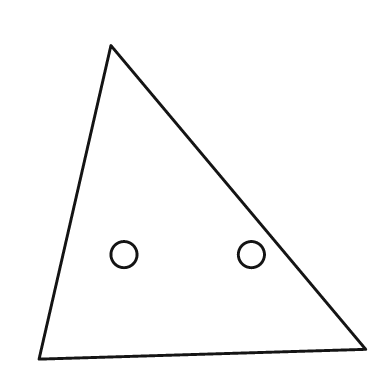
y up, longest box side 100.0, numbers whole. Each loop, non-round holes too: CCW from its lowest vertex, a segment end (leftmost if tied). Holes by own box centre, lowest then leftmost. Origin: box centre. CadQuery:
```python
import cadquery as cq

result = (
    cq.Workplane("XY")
    .moveTo(-50.0, -48.0)
    .lineTo(50.0, -45.0)
    .lineTo(-28.0, 48.0)
    .close()
    .moveTo(-24.0, -16.0)
    .circle(4.0)
    .moveTo(15.0, -16.0)
    .circle(4.0)
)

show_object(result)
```